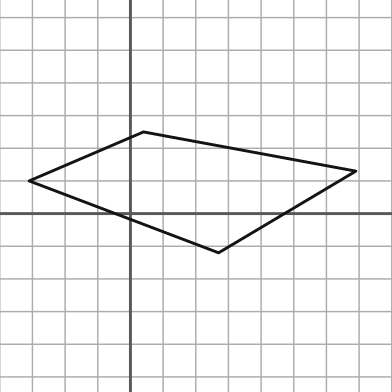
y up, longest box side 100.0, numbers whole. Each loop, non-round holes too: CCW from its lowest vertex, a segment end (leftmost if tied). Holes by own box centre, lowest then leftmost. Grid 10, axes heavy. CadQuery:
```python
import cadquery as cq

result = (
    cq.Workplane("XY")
    .moveTo(27.0, -12.0)
    .lineTo(69.0, 13.0)
    .lineTo(4.0, 25.0)
    .lineTo(-31.0, 10.0)
    .close()
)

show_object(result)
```